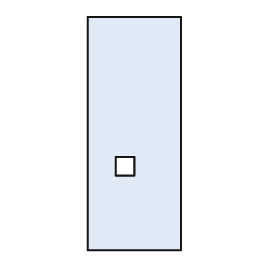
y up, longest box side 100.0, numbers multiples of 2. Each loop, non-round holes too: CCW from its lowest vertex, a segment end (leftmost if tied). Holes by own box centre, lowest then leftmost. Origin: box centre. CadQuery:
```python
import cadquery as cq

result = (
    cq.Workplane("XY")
    .moveTo(-20.0, -50.0)
    .lineTo(20.0, -50.0)
    .lineTo(20.0, 50.0)
    .lineTo(-20.0, 50.0)
    .close()
    .moveTo(-8.0, -18.0)
    .lineTo(0.0, -18.0)
    .lineTo(0.0, -10.0)
    .lineTo(-8.0, -10.0)
    .close()
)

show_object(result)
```